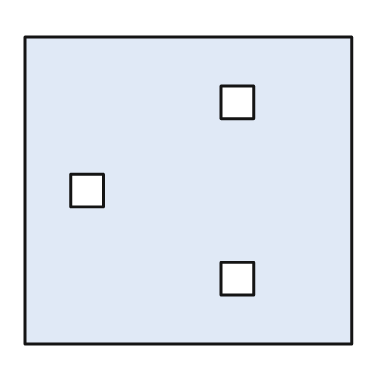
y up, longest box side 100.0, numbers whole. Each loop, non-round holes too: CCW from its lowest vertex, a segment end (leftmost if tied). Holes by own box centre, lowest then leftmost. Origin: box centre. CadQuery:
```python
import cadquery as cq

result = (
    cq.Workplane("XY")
    .moveTo(-50.0, -47.0)
    .lineTo(50.0, -47.0)
    .lineTo(50.0, 47.0)
    .lineTo(-50.0, 47.0)
    .close()
    .moveTo(10.0, -32.0)
    .lineTo(20.0, -32.0)
    .lineTo(20.0, -22.0)
    .lineTo(10.0, -22.0)
    .close()
    .moveTo(-36.0, -5.0)
    .lineTo(-26.0, -5.0)
    .lineTo(-26.0, 5.0)
    .lineTo(-36.0, 5.0)
    .close()
    .moveTo(10.0, 22.0)
    .lineTo(20.0, 22.0)
    .lineTo(20.0, 32.0)
    .lineTo(10.0, 32.0)
    .close()
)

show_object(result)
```